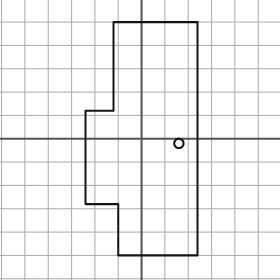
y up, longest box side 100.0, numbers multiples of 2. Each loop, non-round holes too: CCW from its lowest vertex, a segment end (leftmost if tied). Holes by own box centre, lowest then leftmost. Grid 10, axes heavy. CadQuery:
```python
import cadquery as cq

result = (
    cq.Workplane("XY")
    .moveTo(-10.0, -50.0)
    .lineTo(24.0, -50.0)
    .lineTo(24.0, 50.0)
    .lineTo(-12.0, 50.0)
    .lineTo(-12.0, 12.0)
    .lineTo(-24.0, 12.0)
    .lineTo(-24.0, -28.0)
    .lineTo(-10.0, -28.0)
    .close()
    .moveTo(16.0, -2.0)
    .circle(2.0)
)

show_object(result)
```